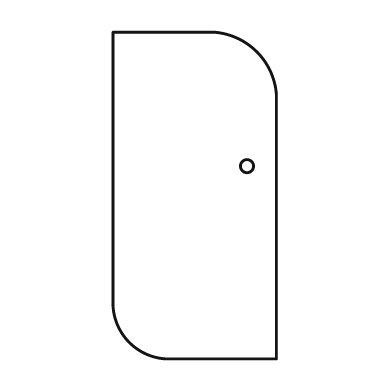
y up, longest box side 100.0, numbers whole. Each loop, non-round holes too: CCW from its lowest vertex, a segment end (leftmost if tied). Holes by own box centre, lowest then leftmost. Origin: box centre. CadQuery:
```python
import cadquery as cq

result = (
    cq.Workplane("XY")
    .moveTo(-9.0, -50.0)
    .lineTo(25.0, -50.0)
    .lineTo(25.0, 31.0)
    .threePointArc((19.0, 44.0), (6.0, 50.0))
    .lineTo(-25.0, 50.0)
    .lineTo(-25.0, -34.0)
    .threePointArc((-20.0, -45.0), (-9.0, -50.0))
    .close()
    .moveTo(16.0, 9.0)
    .circle(2.0)
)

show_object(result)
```